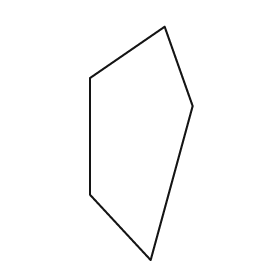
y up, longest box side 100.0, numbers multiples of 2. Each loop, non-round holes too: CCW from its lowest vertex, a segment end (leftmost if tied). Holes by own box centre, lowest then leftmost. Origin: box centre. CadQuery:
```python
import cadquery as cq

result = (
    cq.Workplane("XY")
    .moveTo(4.0, -50.0)
    .lineTo(22.0, 16.0)
    .lineTo(10.0, 50.0)
    .lineTo(-22.0, 28.0)
    .lineTo(-22.0, -22.0)
    .close()
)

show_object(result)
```